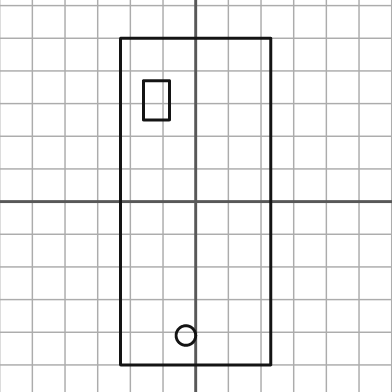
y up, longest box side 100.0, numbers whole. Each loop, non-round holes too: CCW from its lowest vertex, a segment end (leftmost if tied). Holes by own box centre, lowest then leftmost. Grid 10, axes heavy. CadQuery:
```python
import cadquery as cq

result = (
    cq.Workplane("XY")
    .moveTo(-23.0, -50.0)
    .lineTo(23.0, -50.0)
    .lineTo(23.0, 50.0)
    .lineTo(-23.0, 50.0)
    .close()
    .moveTo(-3.0, -41.0)
    .circle(3.0)
    .moveTo(-16.0, 25.0)
    .lineTo(-8.0, 25.0)
    .lineTo(-8.0, 37.0)
    .lineTo(-16.0, 37.0)
    .close()
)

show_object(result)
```